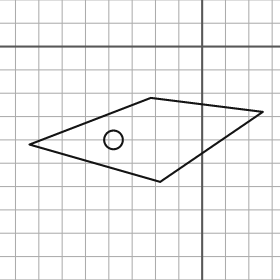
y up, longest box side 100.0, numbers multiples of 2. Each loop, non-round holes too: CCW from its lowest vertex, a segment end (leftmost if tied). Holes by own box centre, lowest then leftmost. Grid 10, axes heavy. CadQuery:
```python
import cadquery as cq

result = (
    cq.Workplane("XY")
    .moveTo(-18.0, -58.0)
    .lineTo(26.0, -28.0)
    .lineTo(-22.0, -22.0)
    .lineTo(-74.0, -42.0)
    .close()
    .moveTo(-38.0, -40.0)
    .circle(4.0)
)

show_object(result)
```